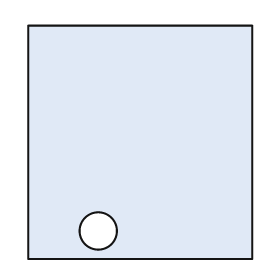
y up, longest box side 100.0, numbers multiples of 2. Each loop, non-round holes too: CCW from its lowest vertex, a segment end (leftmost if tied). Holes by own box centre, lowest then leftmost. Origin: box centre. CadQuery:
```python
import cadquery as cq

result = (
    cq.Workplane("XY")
    .moveTo(-48.0, -50.0)
    .lineTo(48.0, -50.0)
    .lineTo(48.0, 50.0)
    .lineTo(-48.0, 50.0)
    .close()
    .moveTo(-18.0, -38.0)
    .circle(8.0)
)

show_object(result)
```